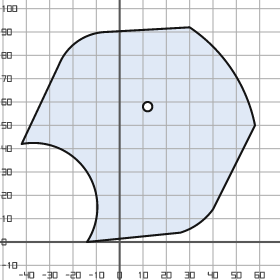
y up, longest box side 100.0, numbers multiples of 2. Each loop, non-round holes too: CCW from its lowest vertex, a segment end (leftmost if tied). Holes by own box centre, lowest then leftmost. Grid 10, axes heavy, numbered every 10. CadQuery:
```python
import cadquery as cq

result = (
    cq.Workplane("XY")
    .moveTo(-14.0, 0.0)
    .lineTo(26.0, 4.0)
    .threePointArc((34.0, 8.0), (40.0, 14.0))
    .lineTo(58.0, 50.0)
    .threePointArc((48.0, 74.0), (30.0, 92.0))
    .lineTo(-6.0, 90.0)
    .threePointArc((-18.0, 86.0), (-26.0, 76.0))
    .lineTo(-42.0, 42.0)
    .threePointArc((-14.0, 30.0), (-14.0, 0.0))
    .close()
    .moveTo(12.0, 58.0)
    .circle(2.0)
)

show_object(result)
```